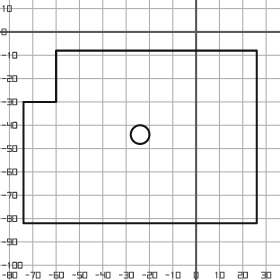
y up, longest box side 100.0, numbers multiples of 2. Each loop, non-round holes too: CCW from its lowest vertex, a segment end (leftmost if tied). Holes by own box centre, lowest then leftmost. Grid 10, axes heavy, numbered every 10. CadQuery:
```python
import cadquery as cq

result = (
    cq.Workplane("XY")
    .moveTo(-74.0, -82.0)
    .lineTo(26.0, -82.0)
    .lineTo(26.0, -8.0)
    .lineTo(-60.0, -8.0)
    .lineTo(-60.0, -30.0)
    .lineTo(-74.0, -30.0)
    .close()
    .moveTo(-24.0, -44.0)
    .circle(4.0)
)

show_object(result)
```